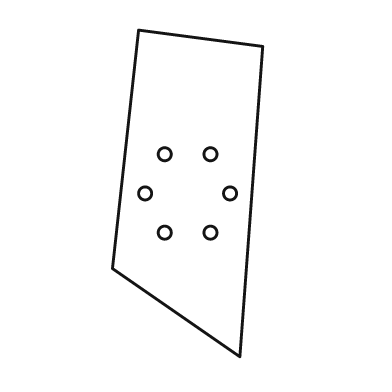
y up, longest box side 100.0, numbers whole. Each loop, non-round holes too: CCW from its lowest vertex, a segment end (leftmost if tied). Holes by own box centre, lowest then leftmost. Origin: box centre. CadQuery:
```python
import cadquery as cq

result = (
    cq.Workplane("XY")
    .moveTo(16.0, -50.0)
    .lineTo(23.0, 45.0)
    .lineTo(-15.0, 50.0)
    .lineTo(-23.0, -23.0)
    .close()
    .moveTo(-7.0, -12.0)
    .circle(2.0)
    .moveTo(7.0, -12.0)
    .circle(2.0)
    .moveTo(-13.0, 0.0)
    .circle(2.0)
    .moveTo(13.0, 0.0)
    .circle(2.0)
    .moveTo(-7.0, 12.0)
    .circle(2.0)
    .moveTo(7.0, 12.0)
    .circle(2.0)
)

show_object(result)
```